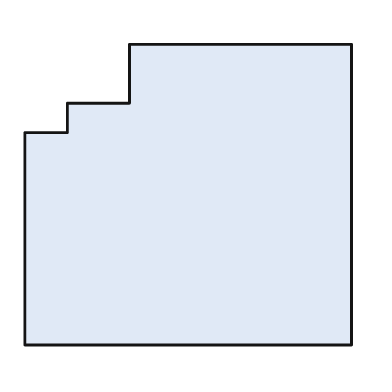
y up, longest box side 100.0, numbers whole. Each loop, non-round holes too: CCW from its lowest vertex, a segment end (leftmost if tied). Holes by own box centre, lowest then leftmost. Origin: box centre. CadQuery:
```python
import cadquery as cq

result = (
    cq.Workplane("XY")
    .moveTo(-50.0, -46.0)
    .lineTo(50.0, -46.0)
    .lineTo(50.0, 46.0)
    .lineTo(-18.0, 46.0)
    .lineTo(-18.0, 28.0)
    .lineTo(-37.0, 28.0)
    .lineTo(-37.0, 19.0)
    .lineTo(-50.0, 19.0)
    .close()
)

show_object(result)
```